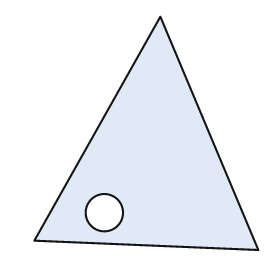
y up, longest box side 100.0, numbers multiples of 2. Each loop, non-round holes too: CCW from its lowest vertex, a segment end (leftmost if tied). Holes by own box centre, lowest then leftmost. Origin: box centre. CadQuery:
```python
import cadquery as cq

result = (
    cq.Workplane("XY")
    .moveTo(48.0, -50.0)
    .lineTo(6.0, 50.0)
    .lineTo(-48.0, -46.0)
    .close()
    .moveTo(-18.0, -34.0)
    .circle(8.0)
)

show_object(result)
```